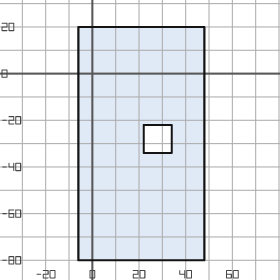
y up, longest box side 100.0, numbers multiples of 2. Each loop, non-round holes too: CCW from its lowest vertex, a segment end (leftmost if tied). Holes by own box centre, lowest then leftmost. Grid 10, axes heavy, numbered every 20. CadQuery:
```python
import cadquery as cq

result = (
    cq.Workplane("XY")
    .moveTo(-6.0, -80.0)
    .lineTo(48.0, -80.0)
    .lineTo(48.0, 20.0)
    .lineTo(-6.0, 20.0)
    .close()
    .moveTo(22.0, -34.0)
    .lineTo(34.0, -34.0)
    .lineTo(34.0, -22.0)
    .lineTo(22.0, -22.0)
    .close()
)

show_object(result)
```